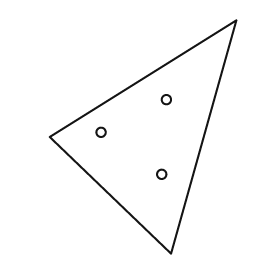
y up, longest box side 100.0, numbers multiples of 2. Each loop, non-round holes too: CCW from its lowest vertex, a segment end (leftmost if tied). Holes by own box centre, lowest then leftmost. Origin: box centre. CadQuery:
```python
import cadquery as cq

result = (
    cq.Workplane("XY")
    .moveTo(12.0, -50.0)
    .lineTo(40.0, 50.0)
    .lineTo(-40.0, 0.0)
    .close()
    .moveTo(8.0, -16.0)
    .circle(2.0)
    .moveTo(-18.0, 2.0)
    .circle(2.0)
    .moveTo(10.0, 16.0)
    .circle(2.0)
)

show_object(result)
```